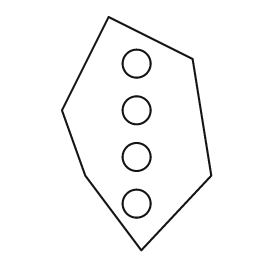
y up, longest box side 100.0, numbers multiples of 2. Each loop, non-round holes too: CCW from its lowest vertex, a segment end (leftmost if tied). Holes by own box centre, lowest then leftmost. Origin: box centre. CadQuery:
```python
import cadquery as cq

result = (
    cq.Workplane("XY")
    .moveTo(2.0, -50.0)
    .lineTo(32.0, -18.0)
    .lineTo(24.0, 32.0)
    .lineTo(-12.0, 50.0)
    .lineTo(-32.0, 10.0)
    .lineTo(-22.0, -18.0)
    .close()
    .moveTo(0.0, -30.0)
    .circle(6.0)
    .moveTo(0.0, -10.0)
    .circle(6.0)
    .moveTo(0.0, 10.0)
    .circle(6.0)
    .moveTo(0.0, 30.0)
    .circle(6.0)
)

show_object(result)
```